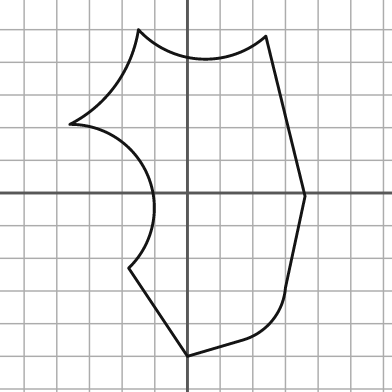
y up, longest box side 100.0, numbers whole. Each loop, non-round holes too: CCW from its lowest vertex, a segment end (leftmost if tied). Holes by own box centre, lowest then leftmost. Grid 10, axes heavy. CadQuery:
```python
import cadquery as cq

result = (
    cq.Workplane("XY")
    .moveTo(0.0, -50.0)
    .lineTo(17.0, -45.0)
    .threePointArc((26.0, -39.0), (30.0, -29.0))
    .lineTo(36.0, -1.0)
    .lineTo(24.0, 48.0)
    .threePointArc((4.0, 41.0), (-15.0, 50.0))
    .threePointArc((-22.0, 33.0), (-36.0, 21.0))
    .threePointArc((-12.0, 5.0), (-18.0, -23.0))
    .close()
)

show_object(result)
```